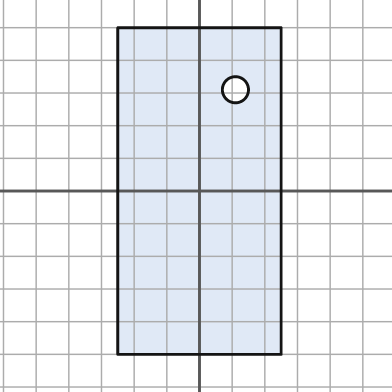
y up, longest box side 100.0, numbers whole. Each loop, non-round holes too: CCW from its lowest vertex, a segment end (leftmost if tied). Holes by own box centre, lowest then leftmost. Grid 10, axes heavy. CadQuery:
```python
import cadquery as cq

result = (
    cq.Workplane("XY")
    .moveTo(-25.0, -50.0)
    .lineTo(25.0, -50.0)
    .lineTo(25.0, 50.0)
    .lineTo(-25.0, 50.0)
    .close()
    .moveTo(11.0, 31.0)
    .circle(4.0)
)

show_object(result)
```